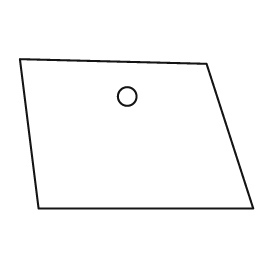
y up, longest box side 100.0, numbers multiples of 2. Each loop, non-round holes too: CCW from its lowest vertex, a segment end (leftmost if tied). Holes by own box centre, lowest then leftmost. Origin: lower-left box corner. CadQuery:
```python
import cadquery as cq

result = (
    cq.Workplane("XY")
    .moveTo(8.0, 0.0)
    .lineTo(100.0, 0.0)
    .lineTo(80.0, 62.0)
    .lineTo(0.0, 64.0)
    .close()
    .moveTo(46.0, 48.0)
    .circle(4.0)
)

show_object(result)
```